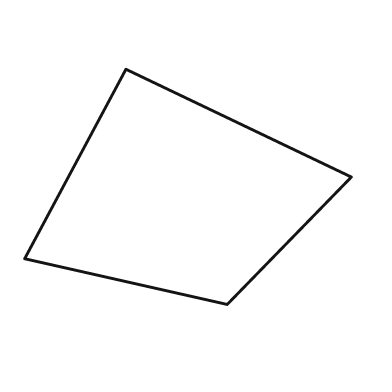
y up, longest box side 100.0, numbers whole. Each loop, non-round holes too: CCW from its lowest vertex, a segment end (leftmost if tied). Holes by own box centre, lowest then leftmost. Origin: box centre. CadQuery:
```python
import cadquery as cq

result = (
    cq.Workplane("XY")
    .moveTo(12.0, -36.0)
    .lineTo(50.0, 3.0)
    .lineTo(-19.0, 36.0)
    .lineTo(-50.0, -22.0)
    .close()
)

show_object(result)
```